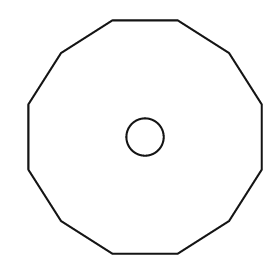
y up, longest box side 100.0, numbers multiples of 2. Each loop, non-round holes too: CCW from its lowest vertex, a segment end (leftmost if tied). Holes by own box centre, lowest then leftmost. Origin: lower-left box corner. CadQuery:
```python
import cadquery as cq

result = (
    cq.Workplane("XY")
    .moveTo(36.0, 0.0)
    .lineTo(64.0, 0.0)
    .lineTo(86.0, 14.0)
    .lineTo(100.0, 36.0)
    .lineTo(100.0, 64.0)
    .lineTo(86.0, 86.0)
    .lineTo(64.0, 100.0)
    .lineTo(36.0, 100.0)
    .lineTo(14.0, 86.0)
    .lineTo(0.0, 64.0)
    .lineTo(0.0, 36.0)
    .lineTo(14.0, 14.0)
    .close()
    .moveTo(50.0, 50.0)
    .circle(8.0)
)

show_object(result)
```